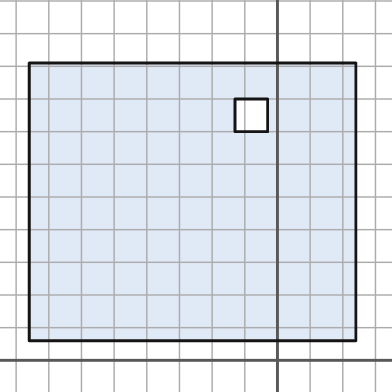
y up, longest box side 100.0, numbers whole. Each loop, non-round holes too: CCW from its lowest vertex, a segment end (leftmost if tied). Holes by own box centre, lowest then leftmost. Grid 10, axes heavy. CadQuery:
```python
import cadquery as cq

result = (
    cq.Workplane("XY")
    .moveTo(-76.0, 6.0)
    .lineTo(24.0, 6.0)
    .lineTo(24.0, 91.0)
    .lineTo(-76.0, 91.0)
    .close()
    .moveTo(-13.0, 70.0)
    .lineTo(-3.0, 70.0)
    .lineTo(-3.0, 80.0)
    .lineTo(-13.0, 80.0)
    .close()
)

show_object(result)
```